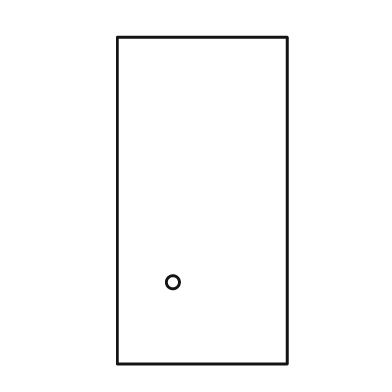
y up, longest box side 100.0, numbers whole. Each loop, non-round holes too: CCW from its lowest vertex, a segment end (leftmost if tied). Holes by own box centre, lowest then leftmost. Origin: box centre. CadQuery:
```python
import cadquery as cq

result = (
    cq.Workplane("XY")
    .moveTo(-26.0, -50.0)
    .lineTo(26.0, -50.0)
    .lineTo(26.0, 50.0)
    .lineTo(-26.0, 50.0)
    .close()
    .moveTo(-9.0, -25.0)
    .circle(2.0)
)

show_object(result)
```